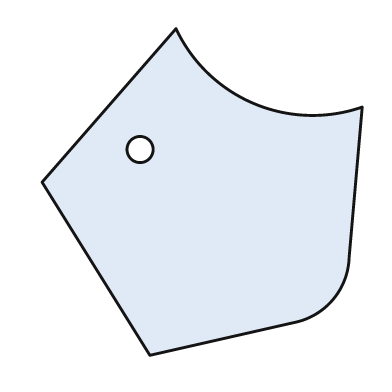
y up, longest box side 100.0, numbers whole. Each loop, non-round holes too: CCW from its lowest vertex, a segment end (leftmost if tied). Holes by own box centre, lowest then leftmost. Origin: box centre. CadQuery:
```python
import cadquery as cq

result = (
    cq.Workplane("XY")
    .moveTo(-16.0, -50.0)
    .lineTo(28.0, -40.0)
    .threePointArc((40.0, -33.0), (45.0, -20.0))
    .lineTo(49.0, 26.0)
    .threePointArc((16.0, 27.0), (-8.0, 50.0))
    .lineTo(-49.0, 3.0)
    .close()
    .moveTo(-19.0, 13.0)
    .circle(4.0)
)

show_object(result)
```